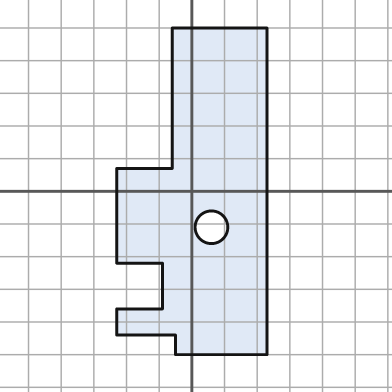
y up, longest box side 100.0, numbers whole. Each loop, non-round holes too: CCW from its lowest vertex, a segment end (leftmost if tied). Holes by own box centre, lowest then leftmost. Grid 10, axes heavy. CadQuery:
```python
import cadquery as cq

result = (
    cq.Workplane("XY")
    .moveTo(-5.0, -50.0)
    .lineTo(23.0, -50.0)
    .lineTo(23.0, 50.0)
    .lineTo(-6.0, 50.0)
    .lineTo(-6.0, 7.0)
    .lineTo(-23.0, 7.0)
    .lineTo(-23.0, -22.0)
    .lineTo(-9.0, -22.0)
    .lineTo(-9.0, -36.0)
    .lineTo(-23.0, -36.0)
    .lineTo(-23.0, -44.0)
    .lineTo(-5.0, -44.0)
    .close()
    .moveTo(6.0, -11.0)
    .circle(5.0)
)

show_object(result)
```